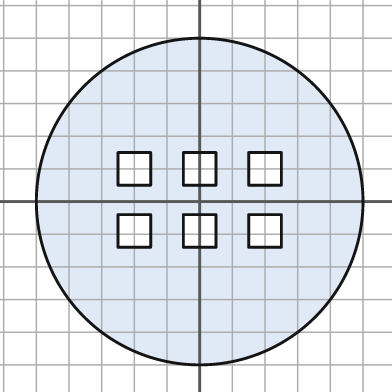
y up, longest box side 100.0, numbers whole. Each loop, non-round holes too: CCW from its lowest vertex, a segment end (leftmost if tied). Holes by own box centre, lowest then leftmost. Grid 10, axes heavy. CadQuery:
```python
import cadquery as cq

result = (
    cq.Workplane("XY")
    .moveTo(0.0, 0.0)
    .circle(50.0)
    .moveTo(-25.0, -14.0)
    .lineTo(-15.0, -14.0)
    .lineTo(-15.0, -4.0)
    .lineTo(-25.0, -4.0)
    .close()
    .moveTo(-5.0, -14.0)
    .lineTo(5.0, -14.0)
    .lineTo(5.0, -4.0)
    .lineTo(-5.0, -4.0)
    .close()
    .moveTo(15.0, -14.0)
    .lineTo(25.0, -14.0)
    .lineTo(25.0, -4.0)
    .lineTo(15.0, -4.0)
    .close()
    .moveTo(-25.0, 5.0)
    .lineTo(-15.0, 5.0)
    .lineTo(-15.0, 15.0)
    .lineTo(-25.0, 15.0)
    .close()
    .moveTo(-5.0, 5.0)
    .lineTo(5.0, 5.0)
    .lineTo(5.0, 15.0)
    .lineTo(-5.0, 15.0)
    .close()
    .moveTo(15.0, 5.0)
    .lineTo(25.0, 5.0)
    .lineTo(25.0, 15.0)
    .lineTo(15.0, 15.0)
    .close()
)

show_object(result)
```